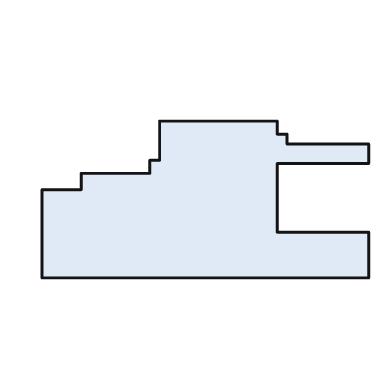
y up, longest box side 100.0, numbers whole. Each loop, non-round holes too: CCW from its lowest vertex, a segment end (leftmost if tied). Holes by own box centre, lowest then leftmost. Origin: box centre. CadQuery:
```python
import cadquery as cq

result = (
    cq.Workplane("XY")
    .moveTo(-50.0, -24.0)
    .lineTo(50.0, -24.0)
    .lineTo(50.0, -10.0)
    .lineTo(22.0, -10.0)
    .lineTo(22.0, 11.0)
    .lineTo(50.0, 11.0)
    .lineTo(50.0, 17.0)
    .lineTo(25.0, 17.0)
    .lineTo(25.0, 20.0)
    .lineTo(22.0, 20.0)
    .lineTo(22.0, 24.0)
    .lineTo(-14.0, 24.0)
    .lineTo(-14.0, 12.0)
    .lineTo(-17.0, 12.0)
    .lineTo(-17.0, 8.0)
    .lineTo(-38.0, 8.0)
    .lineTo(-38.0, 3.0)
    .lineTo(-50.0, 3.0)
    .close()
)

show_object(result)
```